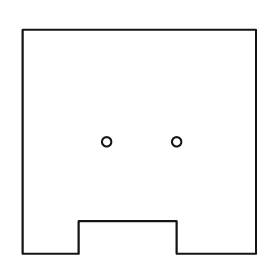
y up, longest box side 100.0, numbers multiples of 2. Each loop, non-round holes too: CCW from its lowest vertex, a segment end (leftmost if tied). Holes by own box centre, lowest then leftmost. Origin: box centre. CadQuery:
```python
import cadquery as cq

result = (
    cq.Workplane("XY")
    .moveTo(-50.0, -48.0)
    .lineTo(-26.0, -48.0)
    .lineTo(-26.0, -34.0)
    .lineTo(16.0, -34.0)
    .lineTo(16.0, -48.0)
    .lineTo(50.0, -48.0)
    .lineTo(50.0, 48.0)
    .lineTo(-50.0, 48.0)
    .close()
    .moveTo(-14.0, 0.0)
    .circle(2.0)
    .moveTo(16.0, 0.0)
    .circle(2.0)
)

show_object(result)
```